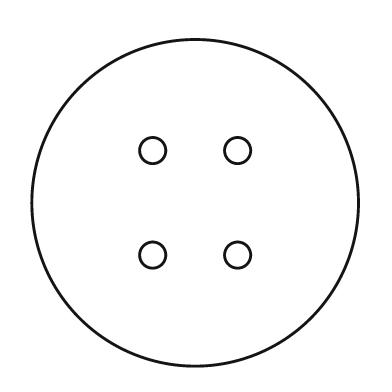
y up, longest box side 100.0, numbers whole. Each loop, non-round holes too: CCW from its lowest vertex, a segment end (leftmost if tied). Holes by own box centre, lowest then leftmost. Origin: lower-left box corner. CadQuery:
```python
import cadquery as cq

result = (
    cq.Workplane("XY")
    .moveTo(50.0, 50.0)
    .circle(50.0)
    .moveTo(37.0, 34.0)
    .circle(4.0)
    .moveTo(63.0, 34.0)
    .circle(4.0)
    .moveTo(37.0, 66.0)
    .circle(4.0)
    .moveTo(63.0, 66.0)
    .circle(4.0)
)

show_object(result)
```